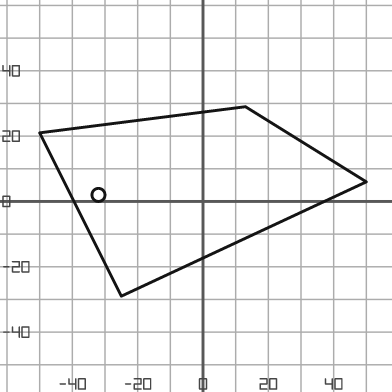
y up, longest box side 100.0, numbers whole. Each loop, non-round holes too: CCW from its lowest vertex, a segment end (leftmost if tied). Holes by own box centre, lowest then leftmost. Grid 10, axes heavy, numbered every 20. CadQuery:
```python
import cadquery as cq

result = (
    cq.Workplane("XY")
    .moveTo(-25.0, -29.0)
    .lineTo(50.0, 6.0)
    .lineTo(13.0, 29.0)
    .lineTo(-50.0, 21.0)
    .close()
    .moveTo(-32.0, 2.0)
    .circle(2.0)
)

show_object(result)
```